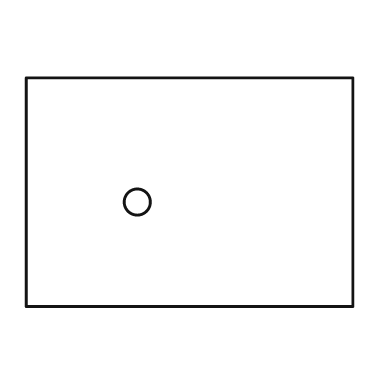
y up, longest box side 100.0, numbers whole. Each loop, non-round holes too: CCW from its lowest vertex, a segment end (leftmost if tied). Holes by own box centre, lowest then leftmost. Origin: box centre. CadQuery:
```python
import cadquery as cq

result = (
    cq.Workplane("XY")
    .moveTo(-50.0, -35.0)
    .lineTo(50.0, -35.0)
    .lineTo(50.0, 35.0)
    .lineTo(-50.0, 35.0)
    .close()
    .moveTo(-16.0, -3.0)
    .circle(4.0)
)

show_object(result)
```